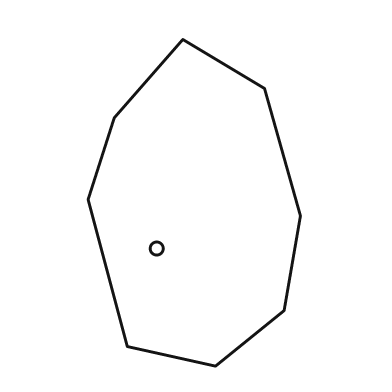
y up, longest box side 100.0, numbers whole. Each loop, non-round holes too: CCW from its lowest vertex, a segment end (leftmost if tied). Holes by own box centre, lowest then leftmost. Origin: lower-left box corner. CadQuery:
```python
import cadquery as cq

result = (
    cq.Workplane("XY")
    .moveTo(39.0, 0.0)
    .lineTo(60.0, 17.0)
    .lineTo(65.0, 46.0)
    .lineTo(54.0, 85.0)
    .lineTo(29.0, 100.0)
    .lineTo(8.0, 76.0)
    .lineTo(0.0, 51.0)
    .lineTo(12.0, 6.0)
    .close()
    .moveTo(21.0, 36.0)
    .circle(2.0)
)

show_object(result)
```